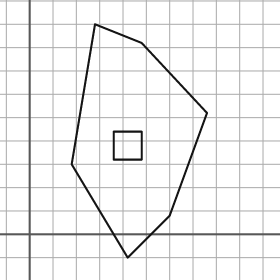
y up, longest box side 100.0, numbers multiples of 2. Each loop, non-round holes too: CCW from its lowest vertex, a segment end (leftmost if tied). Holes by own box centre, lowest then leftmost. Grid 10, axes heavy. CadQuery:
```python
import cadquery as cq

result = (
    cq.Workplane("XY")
    .moveTo(42.0, -10.0)
    .lineTo(60.0, 8.0)
    .lineTo(76.0, 52.0)
    .lineTo(48.0, 82.0)
    .lineTo(28.0, 90.0)
    .lineTo(18.0, 30.0)
    .close()
    .moveTo(36.0, 32.0)
    .lineTo(48.0, 32.0)
    .lineTo(48.0, 44.0)
    .lineTo(36.0, 44.0)
    .close()
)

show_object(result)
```